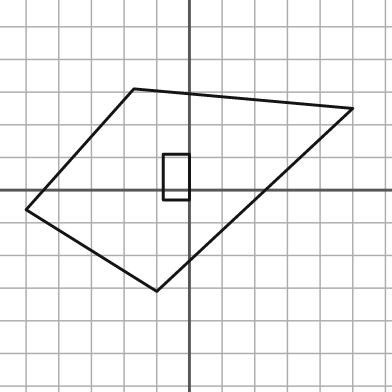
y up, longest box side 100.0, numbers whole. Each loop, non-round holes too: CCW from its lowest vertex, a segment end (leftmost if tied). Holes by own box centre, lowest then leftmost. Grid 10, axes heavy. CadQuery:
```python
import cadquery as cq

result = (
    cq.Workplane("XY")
    .moveTo(-10.0, -31.0)
    .lineTo(50.0, 25.0)
    .lineTo(-17.0, 31.0)
    .lineTo(-50.0, -6.0)
    .close()
    .moveTo(-8.0, -3.0)
    .lineTo(0.0, -3.0)
    .lineTo(0.0, 11.0)
    .lineTo(-8.0, 11.0)
    .close()
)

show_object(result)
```